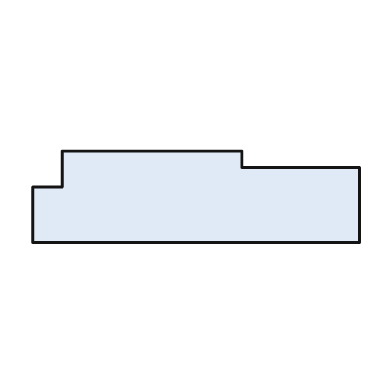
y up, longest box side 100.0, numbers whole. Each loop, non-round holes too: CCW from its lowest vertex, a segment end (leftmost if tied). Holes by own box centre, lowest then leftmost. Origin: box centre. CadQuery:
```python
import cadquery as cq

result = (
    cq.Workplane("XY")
    .moveTo(-50.0, -14.0)
    .lineTo(50.0, -14.0)
    .lineTo(50.0, 9.0)
    .lineTo(14.0, 9.0)
    .lineTo(14.0, 14.0)
    .lineTo(-41.0, 14.0)
    .lineTo(-41.0, 3.0)
    .lineTo(-50.0, 3.0)
    .close()
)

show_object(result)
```